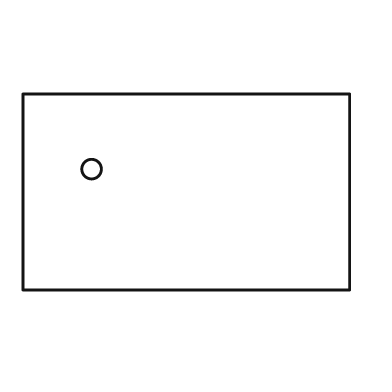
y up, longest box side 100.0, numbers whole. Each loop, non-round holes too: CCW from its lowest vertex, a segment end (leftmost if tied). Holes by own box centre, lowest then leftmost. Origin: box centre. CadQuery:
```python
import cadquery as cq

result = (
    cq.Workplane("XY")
    .moveTo(-50.0, -30.0)
    .lineTo(50.0, -30.0)
    .lineTo(50.0, 30.0)
    .lineTo(-50.0, 30.0)
    .close()
    .moveTo(-29.0, 7.0)
    .circle(3.0)
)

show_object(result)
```